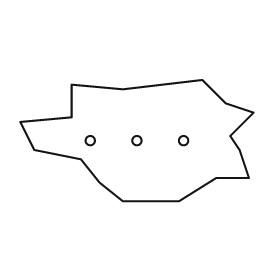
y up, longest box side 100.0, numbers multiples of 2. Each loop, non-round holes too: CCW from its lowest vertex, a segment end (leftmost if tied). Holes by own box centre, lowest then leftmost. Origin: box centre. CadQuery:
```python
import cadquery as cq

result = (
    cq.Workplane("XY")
    .moveTo(-6.0, -26.0)
    .lineTo(18.0, -26.0)
    .lineTo(34.0, -16.0)
    .lineTo(48.0, -16.0)
    .lineTo(44.0, -4.0)
    .lineTo(40.0, 2.0)
    .lineTo(50.0, 12.0)
    .lineTo(38.0, 16.0)
    .lineTo(28.0, 26.0)
    .lineTo(-6.0, 22.0)
    .lineTo(-28.0, 24.0)
    .lineTo(-28.0, 10.0)
    .lineTo(-50.0, 8.0)
    .lineTo(-44.0, -4.0)
    .lineTo(-24.0, -8.0)
    .lineTo(-16.0, -18.0)
    .close()
    .moveTo(-20.0, 0.0)
    .circle(2.0)
    .moveTo(0.0, 0.0)
    .circle(2.0)
    .moveTo(20.0, 0.0)
    .circle(2.0)
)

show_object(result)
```